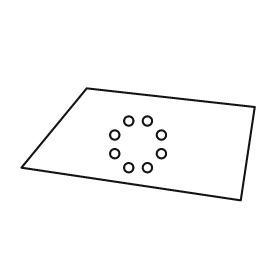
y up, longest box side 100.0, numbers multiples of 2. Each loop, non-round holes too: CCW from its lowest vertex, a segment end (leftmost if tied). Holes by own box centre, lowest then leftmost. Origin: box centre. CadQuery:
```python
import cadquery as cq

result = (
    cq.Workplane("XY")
    .moveTo(44.0, -24.0)
    .lineTo(50.0, 16.0)
    .lineTo(-22.0, 24.0)
    .lineTo(-50.0, -10.0)
    .close()
    .moveTo(-4.0, -10.0)
    .circle(2.0)
    .moveTo(4.0, -10.0)
    .circle(2.0)
    .moveTo(-10.0, -4.0)
    .circle(2.0)
    .moveTo(10.0, -4.0)
    .circle(2.0)
    .moveTo(-10.0, 4.0)
    .circle(2.0)
    .moveTo(10.0, 4.0)
    .circle(2.0)
    .moveTo(-4.0, 10.0)
    .circle(2.0)
    .moveTo(4.0, 10.0)
    .circle(2.0)
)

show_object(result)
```